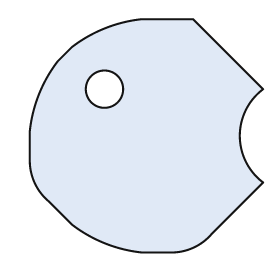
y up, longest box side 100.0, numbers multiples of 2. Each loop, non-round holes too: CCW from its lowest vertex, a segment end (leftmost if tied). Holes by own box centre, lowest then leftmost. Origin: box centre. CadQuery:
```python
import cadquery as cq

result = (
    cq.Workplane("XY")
    .moveTo(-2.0, -50.0)
    .lineTo(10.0, -50.0)
    .threePointArc((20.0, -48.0), (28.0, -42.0))
    .lineTo(50.0, -20.0)
    .threePointArc((40.0, 0.0), (50.0, 20.0))
    .lineTo(20.0, 50.0)
    .lineTo(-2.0, 50.0)
    .threePointArc((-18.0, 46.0), (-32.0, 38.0))
    .lineTo(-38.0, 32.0)
    .threePointArc((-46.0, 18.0), (-50.0, 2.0))
    .lineTo(-50.0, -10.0)
    .threePointArc((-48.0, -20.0), (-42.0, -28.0))
    .lineTo(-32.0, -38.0)
    .threePointArc((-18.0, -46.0), (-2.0, -50.0))
    .close()
    .moveTo(-18.0, 20.0)
    .circle(8.0)
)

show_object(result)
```